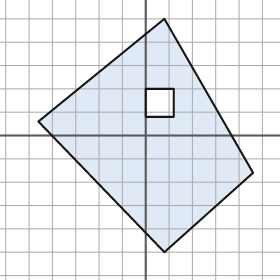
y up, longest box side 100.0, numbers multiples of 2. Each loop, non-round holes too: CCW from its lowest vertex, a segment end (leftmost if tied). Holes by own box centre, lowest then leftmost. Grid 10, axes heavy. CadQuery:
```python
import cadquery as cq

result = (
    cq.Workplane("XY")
    .moveTo(8.0, -50.0)
    .lineTo(46.0, -16.0)
    .lineTo(8.0, 50.0)
    .lineTo(-46.0, 6.0)
    .close()
    .moveTo(0.0, 8.0)
    .lineTo(12.0, 8.0)
    .lineTo(12.0, 20.0)
    .lineTo(0.0, 20.0)
    .close()
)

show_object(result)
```